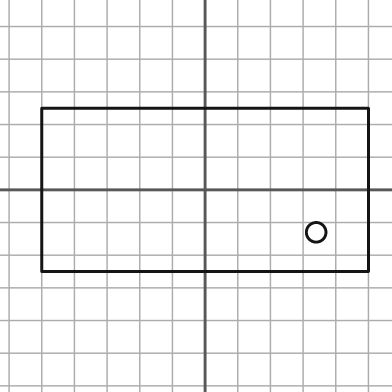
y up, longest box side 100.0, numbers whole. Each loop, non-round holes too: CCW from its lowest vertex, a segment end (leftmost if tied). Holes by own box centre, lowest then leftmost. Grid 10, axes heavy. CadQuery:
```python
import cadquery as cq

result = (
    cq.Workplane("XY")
    .moveTo(-50.0, -25.0)
    .lineTo(50.0, -25.0)
    .lineTo(50.0, 25.0)
    .lineTo(-50.0, 25.0)
    .close()
    .moveTo(34.0, -13.0)
    .circle(3.0)
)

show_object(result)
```